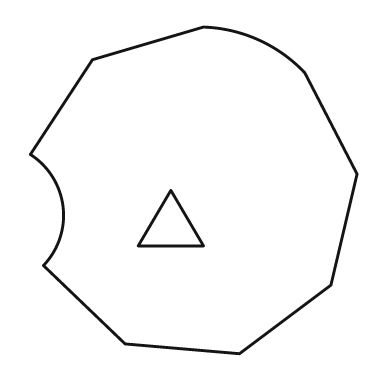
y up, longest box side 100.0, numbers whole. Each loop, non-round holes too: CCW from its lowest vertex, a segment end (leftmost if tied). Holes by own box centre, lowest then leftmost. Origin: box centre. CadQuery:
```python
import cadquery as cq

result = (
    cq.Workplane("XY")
    .moveTo(14.0, -50.0)
    .lineTo(42.0, -29.0)
    .lineTo(50.0, 5.0)
    .lineTo(34.0, 36.0)
    .threePointArc((20.0, 46.0), (3.0, 50.0))
    .lineTo(-31.0, 40.0)
    .lineTo(-50.0, 11.0)
    .threePointArc((-40.0, -5.0), (-46.0, -23.0))
    .lineTo(-21.0, -47.0)
    .close()
    .moveTo(-17.0, -17.0)
    .lineTo(3.0, -17.0)
    .lineTo(-7.0, 0.0)
    .close()
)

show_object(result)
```